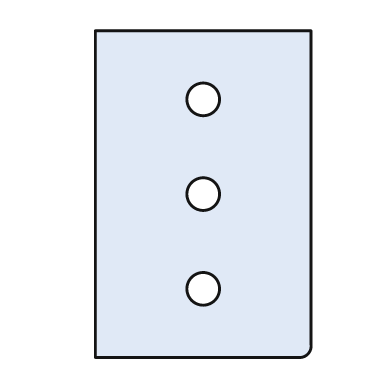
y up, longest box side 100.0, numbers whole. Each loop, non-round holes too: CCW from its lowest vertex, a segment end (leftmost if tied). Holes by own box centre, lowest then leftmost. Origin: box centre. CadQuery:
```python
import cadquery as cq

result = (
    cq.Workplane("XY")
    .moveTo(-33.0, -50.0)
    .lineTo(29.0, -50.0)
    .threePointArc((32.0, -49.0), (33.0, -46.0))
    .lineTo(33.0, 50.0)
    .lineTo(-33.0, 50.0)
    .close()
    .moveTo(0.0, -29.0)
    .circle(5.0)
    .moveTo(0.0, 0.0)
    .circle(5.0)
    .moveTo(0.0, 29.0)
    .circle(5.0)
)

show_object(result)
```